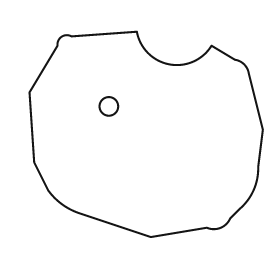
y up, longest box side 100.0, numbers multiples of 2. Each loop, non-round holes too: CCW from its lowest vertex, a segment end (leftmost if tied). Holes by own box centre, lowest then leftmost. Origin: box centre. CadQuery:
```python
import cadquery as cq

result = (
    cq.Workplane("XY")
    .moveTo(2.0, -44.0)
    .lineTo(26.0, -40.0)
    .threePointArc((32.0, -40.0), (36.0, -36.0))
    .lineTo(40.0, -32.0)
    .threePointArc((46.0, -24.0), (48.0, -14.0))
    .lineTo(50.0, 2.0)
    .lineTo(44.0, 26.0)
    .threePointArc((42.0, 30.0), (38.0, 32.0))
    .lineTo(28.0, 38.0)
    .threePointArc((10.0, 30.0), (-4.0, 44.0))
    .lineTo(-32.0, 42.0)
    .threePointArc((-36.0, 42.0), (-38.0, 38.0))
    .lineTo(-50.0, 18.0)
    .lineTo(-48.0, -12.0)
    .lineTo(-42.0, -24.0)
    .threePointArc((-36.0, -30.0), (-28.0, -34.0))
    .close()
    .moveTo(-16.0, 12.0)
    .circle(4.0)
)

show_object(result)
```